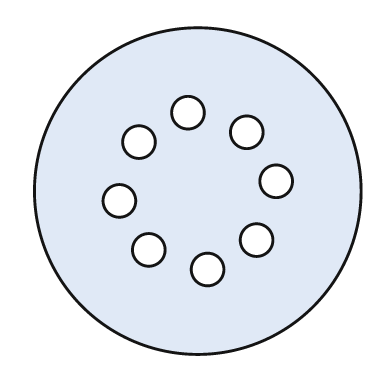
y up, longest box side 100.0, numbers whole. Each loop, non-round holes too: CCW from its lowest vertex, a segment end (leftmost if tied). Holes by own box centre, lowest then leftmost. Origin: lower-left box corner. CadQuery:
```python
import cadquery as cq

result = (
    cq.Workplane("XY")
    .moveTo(50.0, 50.0)
    .circle(50.0)
    .moveTo(53.0, 26.0)
    .circle(5.0)
    .moveTo(35.0, 32.0)
    .circle(5.0)
    .moveTo(68.0, 35.0)
    .circle(5.0)
    .moveTo(26.0, 47.0)
    .circle(5.0)
    .moveTo(74.0, 53.0)
    .circle(5.0)
    .moveTo(32.0, 65.0)
    .circle(5.0)
    .moveTo(65.0, 68.0)
    .circle(5.0)
    .moveTo(47.0, 74.0)
    .circle(5.0)
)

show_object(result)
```